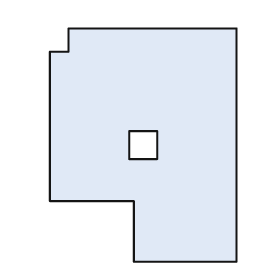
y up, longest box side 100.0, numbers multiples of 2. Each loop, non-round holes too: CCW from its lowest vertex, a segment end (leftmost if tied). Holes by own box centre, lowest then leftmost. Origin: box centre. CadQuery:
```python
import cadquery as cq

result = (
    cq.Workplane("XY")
    .moveTo(-4.0, -50.0)
    .lineTo(40.0, -50.0)
    .lineTo(40.0, 50.0)
    .lineTo(-32.0, 50.0)
    .lineTo(-32.0, 40.0)
    .lineTo(-40.0, 40.0)
    .lineTo(-40.0, -24.0)
    .lineTo(-4.0, -24.0)
    .close()
    .moveTo(-6.0, -6.0)
    .lineTo(6.0, -6.0)
    .lineTo(6.0, 6.0)
    .lineTo(-6.0, 6.0)
    .close()
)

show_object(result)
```